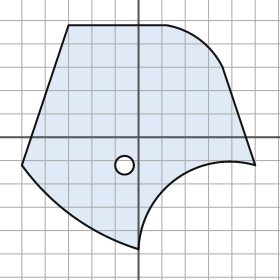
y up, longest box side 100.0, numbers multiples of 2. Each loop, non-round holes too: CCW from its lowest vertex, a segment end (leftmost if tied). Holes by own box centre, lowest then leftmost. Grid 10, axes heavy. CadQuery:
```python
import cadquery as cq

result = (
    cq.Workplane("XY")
    .moveTo(0.0, -48.0)
    .threePointArc((16.0, -18.0), (50.0, -12.0))
    .lineTo(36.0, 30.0)
    .threePointArc((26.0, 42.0), (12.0, 48.0))
    .lineTo(-30.0, 48.0)
    .lineTo(-50.0, -12.0)
    .threePointArc((-28.0, -34.0), (0.0, -48.0))
    .close()
    .moveTo(-6.0, -12.0)
    .circle(4.0)
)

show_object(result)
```